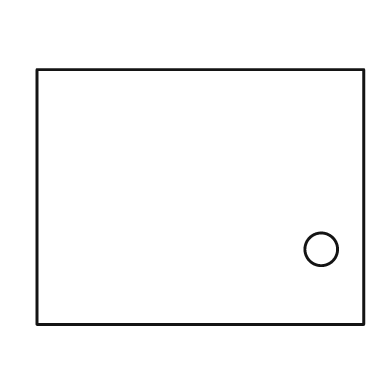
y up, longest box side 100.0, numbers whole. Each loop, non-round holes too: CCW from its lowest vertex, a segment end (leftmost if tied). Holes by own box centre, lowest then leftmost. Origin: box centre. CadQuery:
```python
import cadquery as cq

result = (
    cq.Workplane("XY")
    .moveTo(-50.0, -39.0)
    .lineTo(50.0, -39.0)
    .lineTo(50.0, 39.0)
    .lineTo(-50.0, 39.0)
    .close()
    .moveTo(37.0, -16.0)
    .circle(5.0)
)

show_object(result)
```